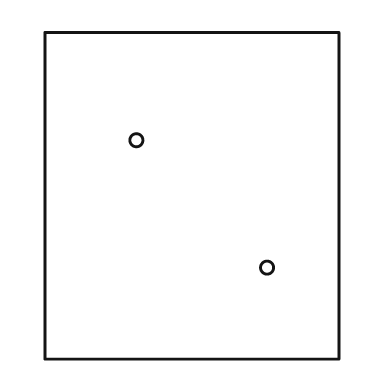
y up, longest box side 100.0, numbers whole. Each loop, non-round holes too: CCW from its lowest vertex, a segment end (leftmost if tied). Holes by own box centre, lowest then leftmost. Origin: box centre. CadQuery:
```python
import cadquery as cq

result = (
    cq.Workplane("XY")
    .moveTo(-45.0, -50.0)
    .lineTo(45.0, -50.0)
    .lineTo(45.0, 50.0)
    .lineTo(-45.0, 50.0)
    .close()
    .moveTo(23.0, -22.0)
    .circle(2.0)
    .moveTo(-17.0, 17.0)
    .circle(2.0)
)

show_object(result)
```